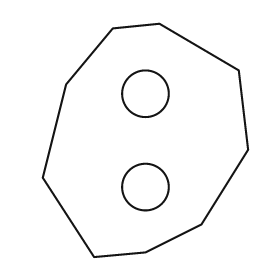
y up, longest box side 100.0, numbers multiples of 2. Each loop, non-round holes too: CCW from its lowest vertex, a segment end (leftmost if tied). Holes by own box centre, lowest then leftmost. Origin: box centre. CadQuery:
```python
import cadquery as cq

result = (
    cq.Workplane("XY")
    .moveTo(-22.0, -50.0)
    .lineTo(0.0, -48.0)
    .lineTo(24.0, -36.0)
    .lineTo(44.0, -4.0)
    .lineTo(40.0, 30.0)
    .lineTo(6.0, 50.0)
    .lineTo(-14.0, 48.0)
    .lineTo(-34.0, 24.0)
    .lineTo(-44.0, -16.0)
    .close()
    .moveTo(0.0, -20.0)
    .circle(10.0)
    .moveTo(0.0, 20.0)
    .circle(10.0)
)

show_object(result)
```